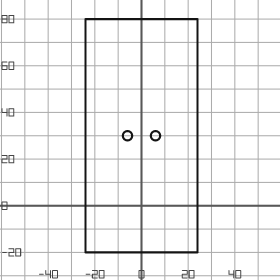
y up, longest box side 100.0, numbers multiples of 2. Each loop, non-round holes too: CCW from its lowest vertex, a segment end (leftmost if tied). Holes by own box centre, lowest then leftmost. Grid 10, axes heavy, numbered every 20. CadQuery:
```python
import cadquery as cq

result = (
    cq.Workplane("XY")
    .moveTo(-24.0, -20.0)
    .lineTo(24.0, -20.0)
    .lineTo(24.0, 80.0)
    .lineTo(-24.0, 80.0)
    .close()
    .moveTo(-6.0, 30.0)
    .circle(2.0)
    .moveTo(6.0, 30.0)
    .circle(2.0)
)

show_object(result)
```